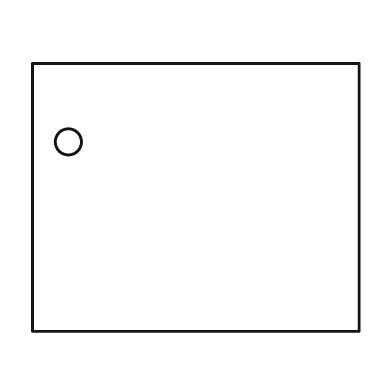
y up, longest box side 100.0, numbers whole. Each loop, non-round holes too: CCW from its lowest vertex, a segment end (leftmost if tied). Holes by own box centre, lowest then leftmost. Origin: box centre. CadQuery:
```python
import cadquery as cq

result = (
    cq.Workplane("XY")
    .moveTo(-50.0, -41.0)
    .lineTo(50.0, -41.0)
    .lineTo(50.0, 41.0)
    .lineTo(-50.0, 41.0)
    .close()
    .moveTo(-39.0, 17.0)
    .circle(4.0)
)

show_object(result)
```